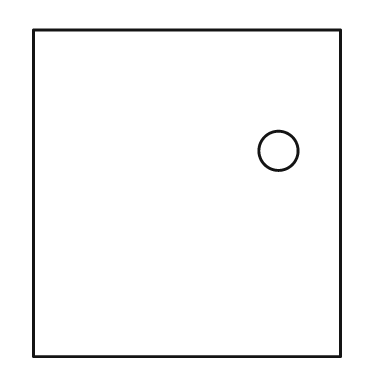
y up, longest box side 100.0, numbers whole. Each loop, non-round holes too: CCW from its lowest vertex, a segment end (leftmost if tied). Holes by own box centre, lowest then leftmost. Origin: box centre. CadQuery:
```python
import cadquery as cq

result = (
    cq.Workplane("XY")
    .moveTo(-47.0, -50.0)
    .lineTo(47.0, -50.0)
    .lineTo(47.0, 50.0)
    .lineTo(-47.0, 50.0)
    .close()
    .moveTo(28.0, 13.0)
    .circle(6.0)
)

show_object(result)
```